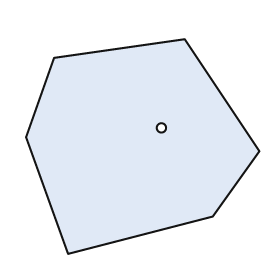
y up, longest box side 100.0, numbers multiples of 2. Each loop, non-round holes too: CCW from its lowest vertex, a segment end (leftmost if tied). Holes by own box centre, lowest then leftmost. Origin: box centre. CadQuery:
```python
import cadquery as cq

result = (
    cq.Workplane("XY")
    .moveTo(-32.0, -46.0)
    .lineTo(30.0, -30.0)
    .lineTo(50.0, -2.0)
    .lineTo(18.0, 46.0)
    .lineTo(-38.0, 38.0)
    .lineTo(-50.0, 4.0)
    .close()
    .moveTo(8.0, 8.0)
    .circle(2.0)
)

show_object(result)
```